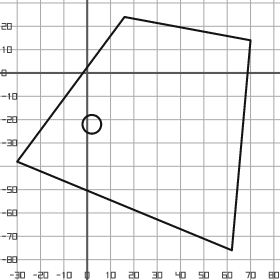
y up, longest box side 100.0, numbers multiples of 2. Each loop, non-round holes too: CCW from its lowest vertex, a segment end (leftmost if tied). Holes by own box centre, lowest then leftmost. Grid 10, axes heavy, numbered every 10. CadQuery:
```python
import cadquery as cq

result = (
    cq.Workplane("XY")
    .moveTo(62.0, -76.0)
    .lineTo(70.0, 14.0)
    .lineTo(16.0, 24.0)
    .lineTo(-30.0, -38.0)
    .close()
    .moveTo(2.0, -22.0)
    .circle(4.0)
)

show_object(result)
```